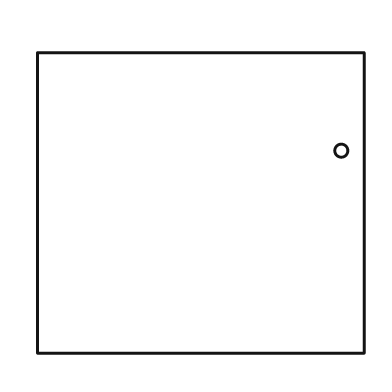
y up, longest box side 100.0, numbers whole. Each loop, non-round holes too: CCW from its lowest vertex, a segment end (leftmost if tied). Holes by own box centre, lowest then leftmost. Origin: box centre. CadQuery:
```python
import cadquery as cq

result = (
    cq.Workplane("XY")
    .moveTo(-50.0, -46.0)
    .lineTo(50.0, -46.0)
    .lineTo(50.0, 46.0)
    .lineTo(-50.0, 46.0)
    .close()
    .moveTo(43.0, 16.0)
    .circle(2.0)
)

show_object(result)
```